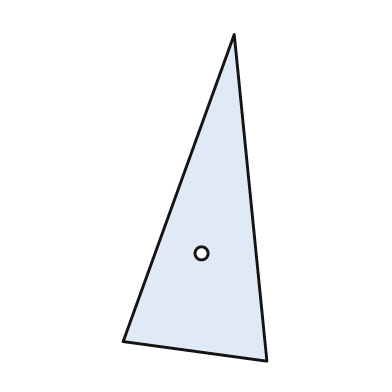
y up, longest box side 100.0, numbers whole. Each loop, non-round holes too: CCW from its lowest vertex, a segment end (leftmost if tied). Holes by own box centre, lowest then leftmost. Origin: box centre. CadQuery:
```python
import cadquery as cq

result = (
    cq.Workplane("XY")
    .moveTo(22.0, -50.0)
    .lineTo(12.0, 50.0)
    .lineTo(-22.0, -44.0)
    .close()
    .moveTo(2.0, -17.0)
    .circle(2.0)
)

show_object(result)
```